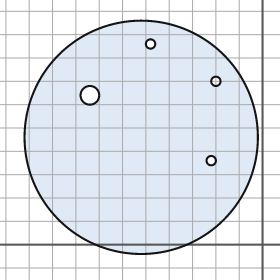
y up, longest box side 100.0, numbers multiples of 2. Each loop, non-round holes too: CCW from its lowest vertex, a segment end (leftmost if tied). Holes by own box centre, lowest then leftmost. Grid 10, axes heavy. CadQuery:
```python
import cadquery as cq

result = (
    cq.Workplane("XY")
    .moveTo(-52.0, 46.0)
    .circle(50.0)
    .moveTo(-22.0, 36.0)
    .circle(2.0)
    .moveTo(-74.0, 64.0)
    .circle(4.0)
    .moveTo(-20.0, 70.0)
    .circle(2.0)
    .moveTo(-48.0, 86.0)
    .circle(2.0)
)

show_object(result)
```